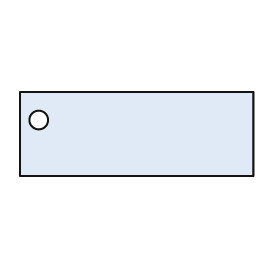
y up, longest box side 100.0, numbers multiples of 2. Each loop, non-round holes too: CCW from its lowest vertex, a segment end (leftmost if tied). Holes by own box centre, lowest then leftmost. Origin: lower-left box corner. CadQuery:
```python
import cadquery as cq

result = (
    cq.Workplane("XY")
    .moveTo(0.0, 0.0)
    .lineTo(100.0, 0.0)
    .lineTo(100.0, 36.0)
    .lineTo(0.0, 36.0)
    .close()
    .moveTo(8.0, 24.0)
    .circle(4.0)
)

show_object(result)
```